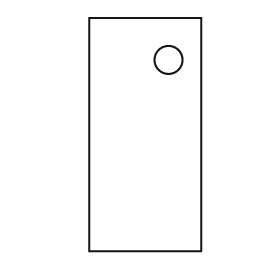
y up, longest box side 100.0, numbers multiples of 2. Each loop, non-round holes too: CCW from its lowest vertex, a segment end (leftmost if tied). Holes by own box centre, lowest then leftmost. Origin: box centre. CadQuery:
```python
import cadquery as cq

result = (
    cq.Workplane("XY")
    .moveTo(-24.0, -50.0)
    .lineTo(24.0, -50.0)
    .lineTo(24.0, 50.0)
    .lineTo(-24.0, 50.0)
    .close()
    .moveTo(10.0, 32.0)
    .circle(6.0)
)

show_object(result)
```